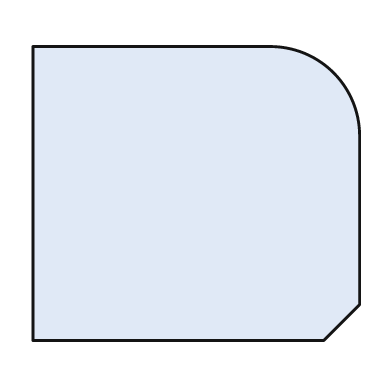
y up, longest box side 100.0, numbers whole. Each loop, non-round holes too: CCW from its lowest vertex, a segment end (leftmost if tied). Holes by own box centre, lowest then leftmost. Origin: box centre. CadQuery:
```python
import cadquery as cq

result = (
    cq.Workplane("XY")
    .moveTo(-50.0, -45.0)
    .lineTo(39.0, -45.0)
    .lineTo(50.0, -34.0)
    .lineTo(50.0, 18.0)
    .threePointArc((42.0, 37.0), (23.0, 45.0))
    .lineTo(-50.0, 45.0)
    .close()
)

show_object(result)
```